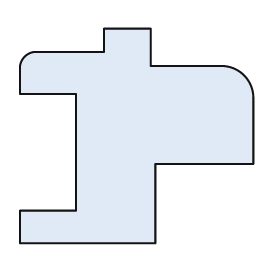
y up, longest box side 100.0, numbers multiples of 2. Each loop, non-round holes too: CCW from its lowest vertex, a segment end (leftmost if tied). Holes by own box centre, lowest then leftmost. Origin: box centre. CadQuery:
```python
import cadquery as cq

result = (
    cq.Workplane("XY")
    .moveTo(-50.0, -46.0)
    .lineTo(8.0, -46.0)
    .lineTo(8.0, -12.0)
    .lineTo(50.0, -12.0)
    .lineTo(50.0, 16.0)
    .threePointArc((46.0, 26.0), (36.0, 30.0))
    .lineTo(6.0, 30.0)
    .lineTo(6.0, 46.0)
    .lineTo(-14.0, 46.0)
    .lineTo(-14.0, 36.0)
    .lineTo(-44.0, 36.0)
    .threePointArc((-48.0, 34.0), (-50.0, 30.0))
    .lineTo(-50.0, 18.0)
    .lineTo(-26.0, 18.0)
    .lineTo(-26.0, -32.0)
    .lineTo(-50.0, -32.0)
    .close()
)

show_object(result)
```